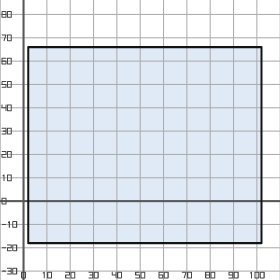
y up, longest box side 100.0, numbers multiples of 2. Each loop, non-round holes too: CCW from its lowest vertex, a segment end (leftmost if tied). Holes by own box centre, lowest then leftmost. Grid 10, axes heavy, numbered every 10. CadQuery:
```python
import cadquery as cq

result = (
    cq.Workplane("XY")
    .moveTo(2.0, -18.0)
    .lineTo(102.0, -18.0)
    .lineTo(102.0, 66.0)
    .lineTo(2.0, 66.0)
    .close()
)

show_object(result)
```